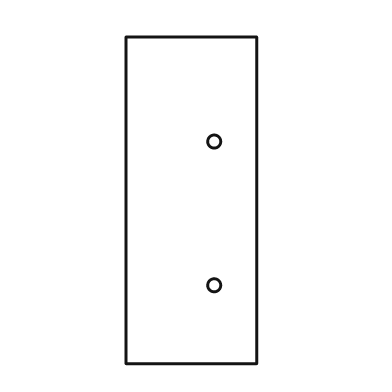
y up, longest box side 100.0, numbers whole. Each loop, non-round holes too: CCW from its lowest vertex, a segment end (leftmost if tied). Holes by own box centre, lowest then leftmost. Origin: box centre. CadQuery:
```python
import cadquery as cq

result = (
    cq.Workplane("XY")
    .moveTo(-20.0, -50.0)
    .lineTo(20.0, -50.0)
    .lineTo(20.0, 50.0)
    .lineTo(-20.0, 50.0)
    .close()
    .moveTo(7.0, -26.0)
    .circle(2.0)
    .moveTo(7.0, 18.0)
    .circle(2.0)
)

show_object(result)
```